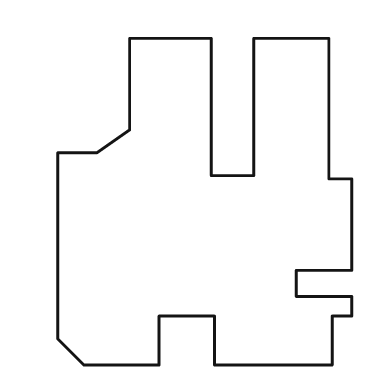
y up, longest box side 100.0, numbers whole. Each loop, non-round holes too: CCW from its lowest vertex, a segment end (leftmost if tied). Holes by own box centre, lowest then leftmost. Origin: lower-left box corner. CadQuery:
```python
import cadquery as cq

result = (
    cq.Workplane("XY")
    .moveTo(8.0, 0.0)
    .lineTo(31.0, 0.0)
    .lineTo(31.0, 15.0)
    .lineTo(48.0, 15.0)
    .lineTo(48.0, 0.0)
    .lineTo(84.0, 0.0)
    .lineTo(84.0, 15.0)
    .lineTo(90.0, 15.0)
    .lineTo(90.0, 21.0)
    .lineTo(73.0, 21.0)
    .lineTo(73.0, 29.0)
    .lineTo(90.0, 29.0)
    .lineTo(90.0, 57.0)
    .lineTo(83.0, 57.0)
    .lineTo(83.0, 100.0)
    .lineTo(60.0, 100.0)
    .lineTo(60.0, 58.0)
    .lineTo(47.0, 58.0)
    .lineTo(47.0, 100.0)
    .lineTo(22.0, 100.0)
    .lineTo(22.0, 72.0)
    .lineTo(12.0, 65.0)
    .lineTo(0.0, 65.0)
    .lineTo(0.0, 8.0)
    .close()
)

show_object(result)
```